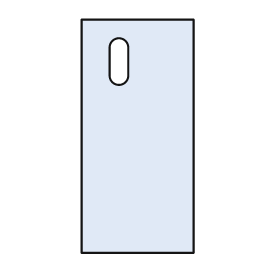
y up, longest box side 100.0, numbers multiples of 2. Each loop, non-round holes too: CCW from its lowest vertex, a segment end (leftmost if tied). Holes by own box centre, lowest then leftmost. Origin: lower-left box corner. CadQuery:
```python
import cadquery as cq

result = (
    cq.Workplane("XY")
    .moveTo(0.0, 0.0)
    .lineTo(48.0, 0.0)
    .lineTo(48.0, 100.0)
    .lineTo(0.0, 100.0)
    .close()
    .moveTo(12.0, 76.0)
    .threePointArc((16.0, 72.0), (20.0, 76.0))
    .lineTo(20.0, 88.0)
    .threePointArc((16.0, 92.0), (12.0, 88.0))
    .close()
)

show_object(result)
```